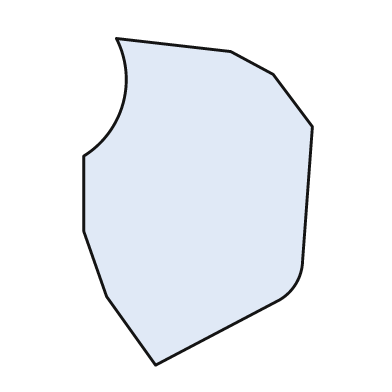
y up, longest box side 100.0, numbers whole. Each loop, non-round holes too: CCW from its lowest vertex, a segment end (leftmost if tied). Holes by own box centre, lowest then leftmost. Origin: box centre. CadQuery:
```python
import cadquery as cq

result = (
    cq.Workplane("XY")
    .moveTo(-13.0, -50.0)
    .lineTo(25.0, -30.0)
    .threePointArc((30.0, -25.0), (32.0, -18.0))
    .lineTo(35.0, 23.0)
    .lineTo(23.0, 39.0)
    .lineTo(10.0, 46.0)
    .lineTo(-25.0, 50.0)
    .threePointArc((-23.0, 30.0), (-35.0, 14.0))
    .lineTo(-35.0, -9.0)
    .lineTo(-28.0, -29.0)
    .close()
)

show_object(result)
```